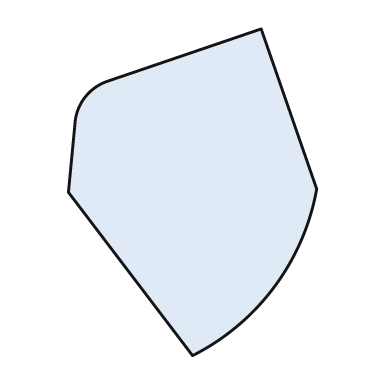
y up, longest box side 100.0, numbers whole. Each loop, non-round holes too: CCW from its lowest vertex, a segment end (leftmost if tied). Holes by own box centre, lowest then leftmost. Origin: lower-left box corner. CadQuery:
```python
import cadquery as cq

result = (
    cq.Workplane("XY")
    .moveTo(38.0, 0.0)
    .threePointArc((63.0, 21.0), (76.0, 51.0))
    .lineTo(59.0, 100.0)
    .lineTo(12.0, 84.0)
    .threePointArc((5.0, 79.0), (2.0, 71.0))
    .lineTo(0.0, 50.0)
    .close()
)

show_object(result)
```